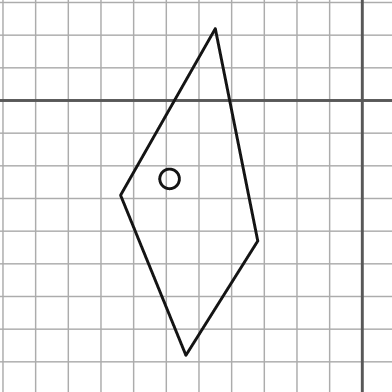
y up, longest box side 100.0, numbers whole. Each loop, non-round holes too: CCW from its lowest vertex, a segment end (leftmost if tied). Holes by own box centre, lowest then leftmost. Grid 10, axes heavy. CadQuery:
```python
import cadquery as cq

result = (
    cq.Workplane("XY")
    .moveTo(-54.0, -78.0)
    .lineTo(-32.0, -43.0)
    .lineTo(-45.0, 22.0)
    .lineTo(-74.0, -29.0)
    .close()
    .moveTo(-59.0, -24.0)
    .circle(3.0)
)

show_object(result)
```